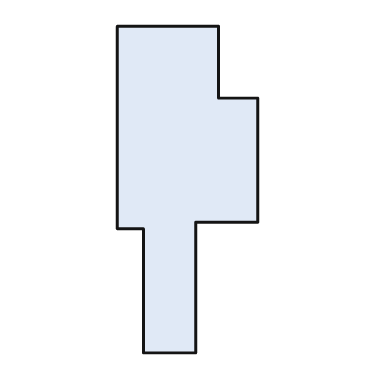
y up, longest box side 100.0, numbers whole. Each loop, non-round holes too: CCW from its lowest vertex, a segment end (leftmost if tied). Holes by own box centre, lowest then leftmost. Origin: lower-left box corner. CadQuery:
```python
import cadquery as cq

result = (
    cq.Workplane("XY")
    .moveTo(8.0, 0.0)
    .lineTo(24.0, 0.0)
    .lineTo(24.0, 40.0)
    .lineTo(43.0, 40.0)
    .lineTo(43.0, 78.0)
    .lineTo(31.0, 78.0)
    .lineTo(31.0, 100.0)
    .lineTo(0.0, 100.0)
    .lineTo(0.0, 38.0)
    .lineTo(8.0, 38.0)
    .close()
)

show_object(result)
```